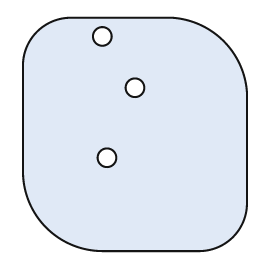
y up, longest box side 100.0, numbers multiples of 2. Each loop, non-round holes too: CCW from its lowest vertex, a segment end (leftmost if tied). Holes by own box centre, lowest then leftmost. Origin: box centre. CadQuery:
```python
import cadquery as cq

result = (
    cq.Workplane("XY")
    .moveTo(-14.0, -50.0)
    .lineTo(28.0, -50.0)
    .threePointArc((42.0, -44.0), (48.0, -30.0))
    .lineTo(48.0, 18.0)
    .threePointArc((38.0, 40.0), (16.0, 50.0))
    .lineTo(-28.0, 50.0)
    .threePointArc((-42.0, 44.0), (-48.0, 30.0))
    .lineTo(-48.0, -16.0)
    .threePointArc((-38.0, -40.0), (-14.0, -50.0))
    .close()
    .moveTo(-12.0, -10.0)
    .circle(4.0)
    .moveTo(0.0, 20.0)
    .circle(4.0)
    .moveTo(-14.0, 42.0)
    .circle(4.0)
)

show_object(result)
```